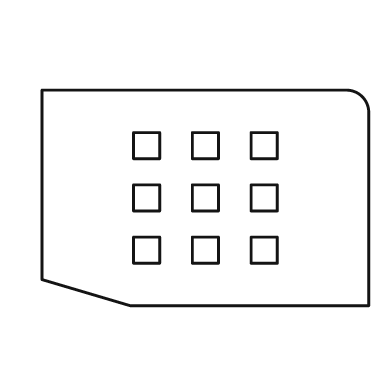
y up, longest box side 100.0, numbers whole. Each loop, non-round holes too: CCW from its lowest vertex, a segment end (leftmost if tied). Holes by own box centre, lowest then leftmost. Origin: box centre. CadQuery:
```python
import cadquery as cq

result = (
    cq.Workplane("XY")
    .moveTo(-23.0, -33.0)
    .lineTo(50.0, -33.0)
    .lineTo(50.0, 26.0)
    .threePointArc((48.0, 31.0), (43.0, 33.0))
    .lineTo(-50.0, 33.0)
    .lineTo(-50.0, -25.0)
    .close()
    .moveTo(-22.0, -20.0)
    .lineTo(-14.0, -20.0)
    .lineTo(-14.0, -12.0)
    .lineTo(-22.0, -12.0)
    .close()
    .moveTo(-4.0, -20.0)
    .lineTo(4.0, -20.0)
    .lineTo(4.0, -12.0)
    .lineTo(-4.0, -12.0)
    .close()
    .moveTo(14.0, -20.0)
    .lineTo(22.0, -20.0)
    .lineTo(22.0, -12.0)
    .lineTo(14.0, -12.0)
    .close()
    .moveTo(-22.0, -4.0)
    .lineTo(-14.0, -4.0)
    .lineTo(-14.0, 4.0)
    .lineTo(-22.0, 4.0)
    .close()
    .moveTo(-4.0, -4.0)
    .lineTo(4.0, -4.0)
    .lineTo(4.0, 4.0)
    .lineTo(-4.0, 4.0)
    .close()
    .moveTo(14.0, -4.0)
    .lineTo(22.0, -4.0)
    .lineTo(22.0, 4.0)
    .lineTo(14.0, 4.0)
    .close()
    .moveTo(-22.0, 12.0)
    .lineTo(-14.0, 12.0)
    .lineTo(-14.0, 20.0)
    .lineTo(-22.0, 20.0)
    .close()
    .moveTo(-4.0, 12.0)
    .lineTo(4.0, 12.0)
    .lineTo(4.0, 20.0)
    .lineTo(-4.0, 20.0)
    .close()
    .moveTo(14.0, 12.0)
    .lineTo(22.0, 12.0)
    .lineTo(22.0, 20.0)
    .lineTo(14.0, 20.0)
    .close()
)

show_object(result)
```